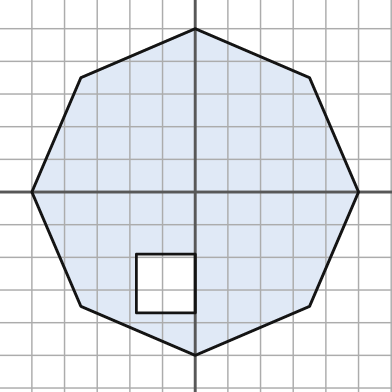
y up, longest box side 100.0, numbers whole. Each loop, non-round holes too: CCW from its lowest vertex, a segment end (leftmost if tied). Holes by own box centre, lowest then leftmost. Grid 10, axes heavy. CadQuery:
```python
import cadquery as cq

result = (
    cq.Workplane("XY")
    .moveTo(0.0, -50.0)
    .lineTo(35.0, -35.0)
    .lineTo(50.0, 0.0)
    .lineTo(35.0, 35.0)
    .lineTo(0.0, 50.0)
    .lineTo(-35.0, 35.0)
    .lineTo(-50.0, 0.0)
    .lineTo(-35.0, -35.0)
    .close()
    .moveTo(-18.0, -37.0)
    .lineTo(0.0, -37.0)
    .lineTo(0.0, -19.0)
    .lineTo(-18.0, -19.0)
    .close()
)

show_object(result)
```